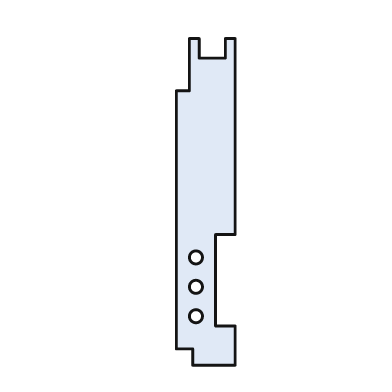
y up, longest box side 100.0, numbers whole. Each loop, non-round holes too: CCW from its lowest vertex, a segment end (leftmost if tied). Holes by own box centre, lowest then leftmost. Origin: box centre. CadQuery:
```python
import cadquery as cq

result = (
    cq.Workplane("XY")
    .moveTo(-4.0, -50.0)
    .lineTo(9.0, -50.0)
    .lineTo(9.0, -38.0)
    .lineTo(3.0, -38.0)
    .lineTo(3.0, -10.0)
    .lineTo(9.0, -10.0)
    .lineTo(9.0, 50.0)
    .lineTo(6.0, 50.0)
    .lineTo(6.0, 44.0)
    .lineTo(-2.0, 44.0)
    .lineTo(-2.0, 50.0)
    .lineTo(-5.0, 50.0)
    .lineTo(-5.0, 34.0)
    .lineTo(-9.0, 34.0)
    .lineTo(-9.0, -45.0)
    .lineTo(-4.0, -45.0)
    .close()
    .moveTo(-3.0, -35.0)
    .circle(2.0)
    .moveTo(-3.0, -26.0)
    .circle(2.0)
    .moveTo(-3.0, -17.0)
    .circle(2.0)
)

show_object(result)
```